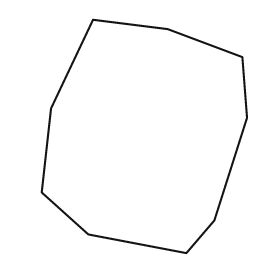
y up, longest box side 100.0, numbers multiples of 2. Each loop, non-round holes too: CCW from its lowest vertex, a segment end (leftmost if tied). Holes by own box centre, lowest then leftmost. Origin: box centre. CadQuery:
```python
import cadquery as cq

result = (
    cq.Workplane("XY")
    .moveTo(18.0, -50.0)
    .lineTo(30.0, -36.0)
    .lineTo(44.0, 8.0)
    .lineTo(42.0, 34.0)
    .lineTo(10.0, 46.0)
    .lineTo(-22.0, 50.0)
    .lineTo(-40.0, 12.0)
    .lineTo(-44.0, -24.0)
    .lineTo(-24.0, -42.0)
    .close()
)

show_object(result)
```